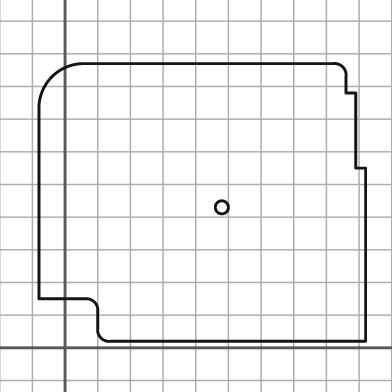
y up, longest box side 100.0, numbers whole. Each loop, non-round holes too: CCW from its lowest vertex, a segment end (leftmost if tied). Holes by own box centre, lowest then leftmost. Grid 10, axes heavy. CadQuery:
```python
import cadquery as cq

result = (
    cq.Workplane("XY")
    .moveTo(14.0, 2.0)
    .lineTo(92.0, 2.0)
    .lineTo(92.0, 55.0)
    .lineTo(89.0, 55.0)
    .lineTo(89.0, 78.0)
    .lineTo(86.0, 78.0)
    .lineTo(86.0, 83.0)
    .threePointArc((85.0, 86.0), (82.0, 87.0))
    .lineTo(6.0, 87.0)
    .threePointArc((-4.0, 83.0), (-8.0, 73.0))
    .lineTo(-8.0, 15.0)
    .lineTo(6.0, 15.0)
    .threePointArc((9.0, 14.0), (10.0, 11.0))
    .lineTo(10.0, 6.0)
    .threePointArc((11.0, 3.0), (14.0, 2.0))
    .close()
    .moveTo(48.0, 43.0)
    .circle(2.0)
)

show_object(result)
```